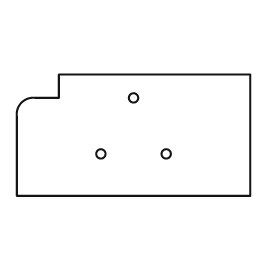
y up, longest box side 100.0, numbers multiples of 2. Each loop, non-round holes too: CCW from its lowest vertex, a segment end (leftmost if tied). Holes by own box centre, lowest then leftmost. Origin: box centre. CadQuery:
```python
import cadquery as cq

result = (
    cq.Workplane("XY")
    .moveTo(-50.0, -26.0)
    .lineTo(50.0, -26.0)
    .lineTo(50.0, 26.0)
    .lineTo(-32.0, 26.0)
    .lineTo(-32.0, 16.0)
    .lineTo(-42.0, 16.0)
    .threePointArc((-48.0, 14.0), (-50.0, 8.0))
    .close()
    .moveTo(-14.0, -8.0)
    .circle(2.0)
    .moveTo(14.0, -8.0)
    .circle(2.0)
    .moveTo(0.0, 16.0)
    .circle(2.0)
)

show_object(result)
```